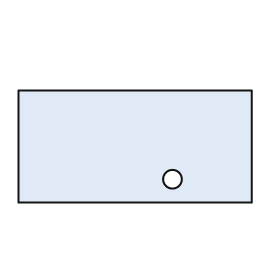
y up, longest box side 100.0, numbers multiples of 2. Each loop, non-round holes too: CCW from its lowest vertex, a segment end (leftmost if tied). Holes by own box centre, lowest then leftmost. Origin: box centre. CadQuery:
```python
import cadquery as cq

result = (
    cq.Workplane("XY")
    .moveTo(-50.0, -24.0)
    .lineTo(50.0, -24.0)
    .lineTo(50.0, 24.0)
    .lineTo(-50.0, 24.0)
    .close()
    .moveTo(16.0, -14.0)
    .circle(4.0)
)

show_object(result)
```